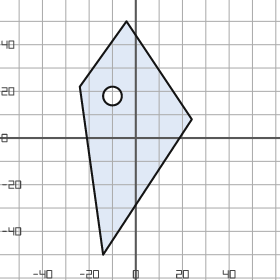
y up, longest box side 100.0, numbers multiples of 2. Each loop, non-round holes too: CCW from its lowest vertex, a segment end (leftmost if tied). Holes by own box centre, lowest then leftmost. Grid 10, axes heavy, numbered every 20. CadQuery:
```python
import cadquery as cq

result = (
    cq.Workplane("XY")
    .moveTo(-14.0, -50.0)
    .lineTo(24.0, 8.0)
    .lineTo(-4.0, 50.0)
    .lineTo(-24.0, 22.0)
    .close()
    .moveTo(-10.0, 18.0)
    .circle(4.0)
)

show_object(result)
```